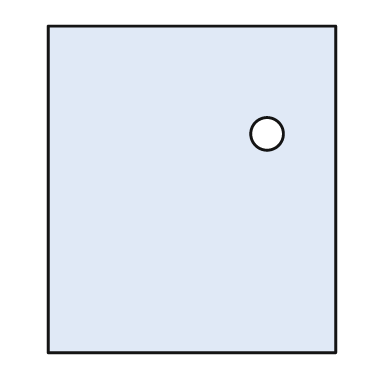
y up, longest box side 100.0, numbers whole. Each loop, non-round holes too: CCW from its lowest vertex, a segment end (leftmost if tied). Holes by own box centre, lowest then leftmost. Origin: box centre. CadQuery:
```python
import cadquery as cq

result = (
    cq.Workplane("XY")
    .moveTo(-44.0, -50.0)
    .lineTo(44.0, -50.0)
    .lineTo(44.0, 50.0)
    .lineTo(-44.0, 50.0)
    .close()
    .moveTo(23.0, 17.0)
    .circle(5.0)
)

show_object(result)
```